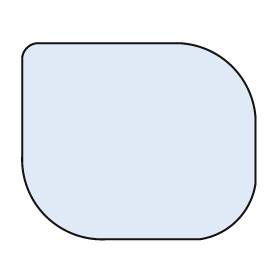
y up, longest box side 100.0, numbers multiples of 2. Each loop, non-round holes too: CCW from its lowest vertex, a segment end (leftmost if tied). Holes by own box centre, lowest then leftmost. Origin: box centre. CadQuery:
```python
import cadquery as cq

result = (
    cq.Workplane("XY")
    .moveTo(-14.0, -42.0)
    .lineTo(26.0, -42.0)
    .threePointArc((42.0, -34.0), (50.0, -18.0))
    .lineTo(50.0, 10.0)
    .threePointArc((40.0, 32.0), (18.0, 42.0))
    .lineTo(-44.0, 42.0)
    .threePointArc((-48.0, 40.0), (-50.0, 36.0))
    .lineTo(-50.0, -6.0)
    .threePointArc((-40.0, -32.0), (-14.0, -42.0))
    .close()
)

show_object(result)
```